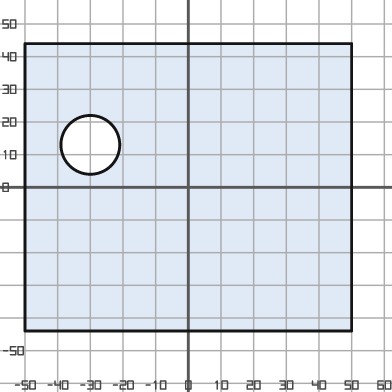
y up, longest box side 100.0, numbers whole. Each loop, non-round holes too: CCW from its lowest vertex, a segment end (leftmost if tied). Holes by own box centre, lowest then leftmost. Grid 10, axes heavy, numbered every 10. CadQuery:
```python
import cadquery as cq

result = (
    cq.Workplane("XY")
    .moveTo(-50.0, -44.0)
    .lineTo(50.0, -44.0)
    .lineTo(50.0, 44.0)
    .lineTo(-50.0, 44.0)
    .close()
    .moveTo(-30.0, 13.0)
    .circle(9.0)
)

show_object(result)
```